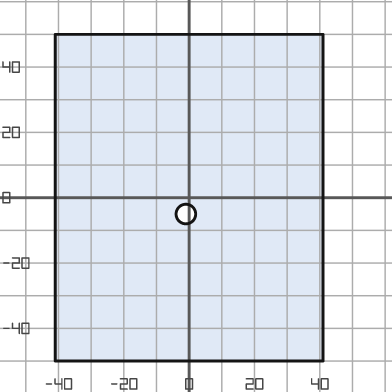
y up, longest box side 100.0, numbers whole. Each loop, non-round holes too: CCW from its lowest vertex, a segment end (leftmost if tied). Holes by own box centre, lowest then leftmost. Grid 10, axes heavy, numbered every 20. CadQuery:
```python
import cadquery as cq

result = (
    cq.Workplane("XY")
    .moveTo(-41.0, -50.0)
    .lineTo(41.0, -50.0)
    .lineTo(41.0, 50.0)
    .lineTo(-41.0, 50.0)
    .close()
    .moveTo(-1.0, -5.0)
    .circle(3.0)
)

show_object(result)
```